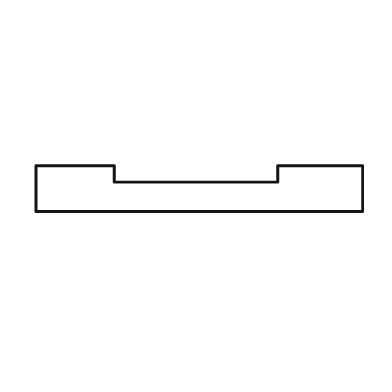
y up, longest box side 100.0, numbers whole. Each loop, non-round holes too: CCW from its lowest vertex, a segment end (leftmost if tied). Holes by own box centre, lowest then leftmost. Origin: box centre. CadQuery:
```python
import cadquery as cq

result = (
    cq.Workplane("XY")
    .moveTo(-50.0, -7.0)
    .lineTo(50.0, -7.0)
    .lineTo(50.0, 7.0)
    .lineTo(24.0, 7.0)
    .lineTo(24.0, 2.0)
    .lineTo(-26.0, 2.0)
    .lineTo(-26.0, 7.0)
    .lineTo(-50.0, 7.0)
    .close()
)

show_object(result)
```